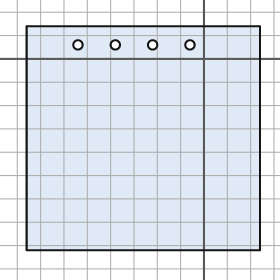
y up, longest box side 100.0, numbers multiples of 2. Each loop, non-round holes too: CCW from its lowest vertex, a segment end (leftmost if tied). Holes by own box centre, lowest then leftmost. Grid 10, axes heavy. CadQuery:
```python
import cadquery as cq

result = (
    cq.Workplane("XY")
    .moveTo(-76.0, -82.0)
    .lineTo(24.0, -82.0)
    .lineTo(24.0, 14.0)
    .lineTo(-76.0, 14.0)
    .close()
    .moveTo(-54.0, 6.0)
    .circle(2.0)
    .moveTo(-38.0, 6.0)
    .circle(2.0)
    .moveTo(-22.0, 6.0)
    .circle(2.0)
    .moveTo(-6.0, 6.0)
    .circle(2.0)
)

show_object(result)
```